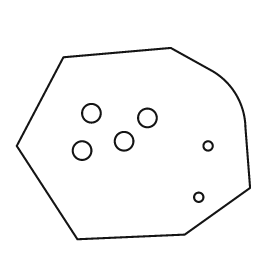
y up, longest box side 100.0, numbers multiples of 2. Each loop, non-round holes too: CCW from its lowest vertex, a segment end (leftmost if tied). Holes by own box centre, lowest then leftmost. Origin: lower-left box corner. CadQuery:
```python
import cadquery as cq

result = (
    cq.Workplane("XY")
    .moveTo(26.0, 0.0)
    .lineTo(72.0, 2.0)
    .lineTo(100.0, 22.0)
    .lineTo(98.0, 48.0)
    .threePointArc((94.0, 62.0), (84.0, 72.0))
    .lineTo(66.0, 82.0)
    .lineTo(20.0, 78.0)
    .lineTo(0.0, 40.0)
    .close()
    .moveTo(78.0, 18.0)
    .circle(2.0)
    .moveTo(28.0, 38.0)
    .circle(4.0)
    .moveTo(82.0, 40.0)
    .circle(2.0)
    .moveTo(46.0, 42.0)
    .circle(4.0)
    .moveTo(56.0, 52.0)
    .circle(4.0)
    .moveTo(32.0, 54.0)
    .circle(4.0)
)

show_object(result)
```